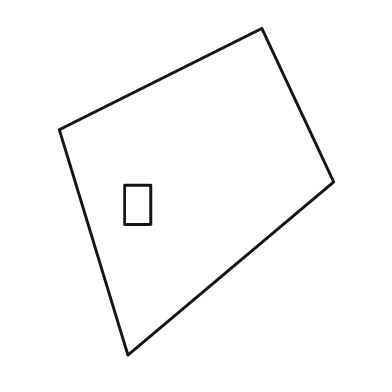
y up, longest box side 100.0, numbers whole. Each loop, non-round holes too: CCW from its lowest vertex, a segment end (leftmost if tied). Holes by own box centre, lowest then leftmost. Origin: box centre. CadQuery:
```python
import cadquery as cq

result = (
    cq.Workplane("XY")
    .moveTo(-21.0, -50.0)
    .lineTo(42.0, 3.0)
    .lineTo(20.0, 50.0)
    .lineTo(-42.0, 19.0)
    .close()
    .moveTo(-22.0, -10.0)
    .lineTo(-14.0, -10.0)
    .lineTo(-14.0, 2.0)
    .lineTo(-22.0, 2.0)
    .close()
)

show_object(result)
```